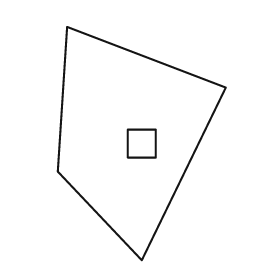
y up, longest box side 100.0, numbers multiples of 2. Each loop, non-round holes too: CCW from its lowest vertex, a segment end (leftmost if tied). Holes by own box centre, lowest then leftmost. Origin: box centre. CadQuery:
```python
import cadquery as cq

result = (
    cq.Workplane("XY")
    .moveTo(0.0, -50.0)
    .lineTo(36.0, 24.0)
    .lineTo(-32.0, 50.0)
    .lineTo(-36.0, -12.0)
    .close()
    .moveTo(-6.0, -6.0)
    .lineTo(6.0, -6.0)
    .lineTo(6.0, 6.0)
    .lineTo(-6.0, 6.0)
    .close()
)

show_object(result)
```